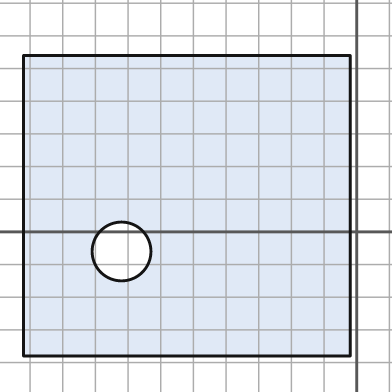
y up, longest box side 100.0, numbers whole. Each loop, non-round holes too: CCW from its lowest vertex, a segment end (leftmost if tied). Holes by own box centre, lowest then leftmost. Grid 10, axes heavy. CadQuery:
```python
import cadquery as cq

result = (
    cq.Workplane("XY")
    .moveTo(-102.0, -38.0)
    .lineTo(-2.0, -38.0)
    .lineTo(-2.0, 54.0)
    .lineTo(-102.0, 54.0)
    .close()
    .moveTo(-72.0, -6.0)
    .circle(9.0)
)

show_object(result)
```